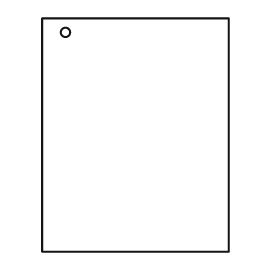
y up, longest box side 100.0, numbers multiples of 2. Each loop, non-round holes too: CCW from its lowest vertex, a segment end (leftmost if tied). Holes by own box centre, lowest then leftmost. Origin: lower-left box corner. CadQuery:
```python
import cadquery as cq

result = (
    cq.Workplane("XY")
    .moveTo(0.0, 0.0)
    .lineTo(80.0, 0.0)
    .lineTo(80.0, 100.0)
    .lineTo(0.0, 100.0)
    .close()
    .moveTo(10.0, 94.0)
    .circle(2.0)
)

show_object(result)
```